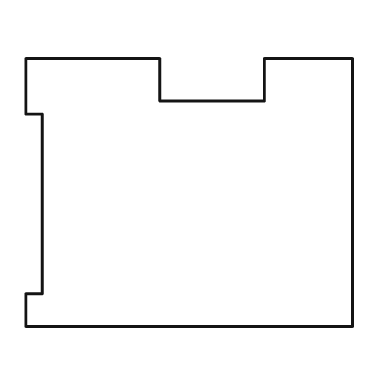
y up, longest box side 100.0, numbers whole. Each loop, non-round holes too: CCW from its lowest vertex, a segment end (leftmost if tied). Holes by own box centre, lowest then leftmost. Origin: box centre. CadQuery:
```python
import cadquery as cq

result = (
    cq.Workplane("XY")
    .moveTo(-50.0, -41.0)
    .lineTo(50.0, -41.0)
    .lineTo(50.0, 41.0)
    .lineTo(23.0, 41.0)
    .lineTo(23.0, 28.0)
    .lineTo(-9.0, 28.0)
    .lineTo(-9.0, 41.0)
    .lineTo(-50.0, 41.0)
    .lineTo(-50.0, 24.0)
    .lineTo(-45.0, 24.0)
    .lineTo(-45.0, -31.0)
    .lineTo(-50.0, -31.0)
    .close()
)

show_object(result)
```